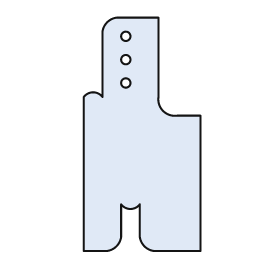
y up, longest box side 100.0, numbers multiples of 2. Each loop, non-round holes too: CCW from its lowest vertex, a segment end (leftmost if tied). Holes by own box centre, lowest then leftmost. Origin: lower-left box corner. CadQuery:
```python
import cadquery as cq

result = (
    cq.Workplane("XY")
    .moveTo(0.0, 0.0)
    .lineTo(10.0, 0.0)
    .threePointArc((14.0, 2.0), (16.0, 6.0))
    .lineTo(16.0, 20.0)
    .threePointArc((20.0, 18.0), (24.0, 20.0))
    .lineTo(24.0, 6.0)
    .threePointArc((26.0, 2.0), (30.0, 0.0))
    .lineTo(50.0, 0.0)
    .lineTo(50.0, 58.0)
    .lineTo(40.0, 58.0)
    .threePointArc((34.0, 60.0), (32.0, 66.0))
    .lineTo(32.0, 100.0)
    .lineTo(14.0, 100.0)
    .threePointArc((10.0, 98.0), (8.0, 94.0))
    .lineTo(8.0, 66.0)
    .threePointArc((4.0, 68.0), (0.0, 66.0))
    .close()
    .moveTo(18.0, 72.0)
    .circle(2.0)
    .moveTo(18.0, 82.0)
    .circle(2.0)
    .moveTo(18.0, 92.0)
    .circle(2.0)
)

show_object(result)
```